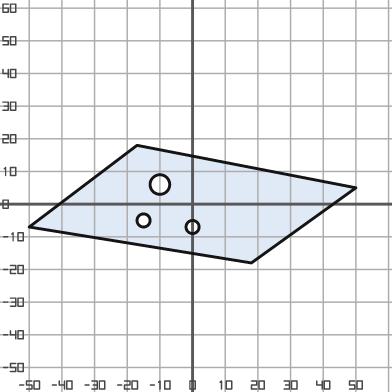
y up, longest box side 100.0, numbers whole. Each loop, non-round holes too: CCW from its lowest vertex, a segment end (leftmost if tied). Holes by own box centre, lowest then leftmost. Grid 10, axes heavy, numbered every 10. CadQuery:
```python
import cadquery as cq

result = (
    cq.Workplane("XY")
    .moveTo(18.0, -18.0)
    .lineTo(50.0, 5.0)
    .lineTo(-17.0, 18.0)
    .lineTo(-50.0, -7.0)
    .close()
    .moveTo(0.0, -7.0)
    .circle(2.0)
    .moveTo(-15.0, -5.0)
    .circle(2.0)
    .moveTo(-10.0, 6.0)
    .circle(3.0)
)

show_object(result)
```